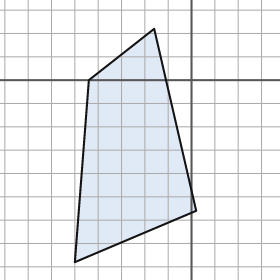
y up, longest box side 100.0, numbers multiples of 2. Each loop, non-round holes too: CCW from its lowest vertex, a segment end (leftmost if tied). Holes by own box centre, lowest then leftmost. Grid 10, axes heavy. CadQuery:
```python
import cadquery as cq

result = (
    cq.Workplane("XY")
    .moveTo(-50.0, -78.0)
    .lineTo(2.0, -56.0)
    .lineTo(-16.0, 22.0)
    .lineTo(-44.0, 0.0)
    .close()
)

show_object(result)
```